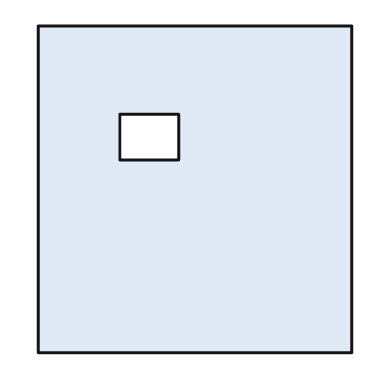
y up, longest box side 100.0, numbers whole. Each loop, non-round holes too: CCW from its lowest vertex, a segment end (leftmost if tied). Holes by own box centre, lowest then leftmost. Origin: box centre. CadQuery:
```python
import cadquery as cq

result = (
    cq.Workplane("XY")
    .moveTo(-48.0, -50.0)
    .lineTo(48.0, -50.0)
    .lineTo(48.0, 50.0)
    .lineTo(-48.0, 50.0)
    .close()
    .moveTo(-23.0, 9.0)
    .lineTo(-5.0, 9.0)
    .lineTo(-5.0, 23.0)
    .lineTo(-23.0, 23.0)
    .close()
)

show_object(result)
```